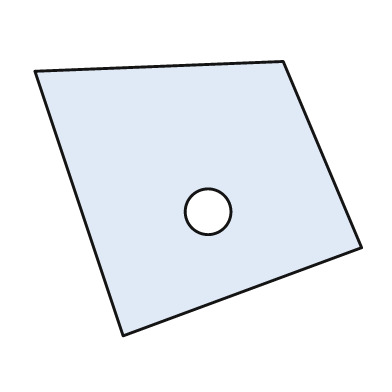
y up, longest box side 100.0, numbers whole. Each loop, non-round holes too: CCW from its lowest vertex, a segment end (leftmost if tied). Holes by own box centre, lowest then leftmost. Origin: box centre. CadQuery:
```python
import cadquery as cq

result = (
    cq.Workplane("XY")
    .moveTo(-23.0, -42.0)
    .lineTo(50.0, -15.0)
    .lineTo(26.0, 42.0)
    .lineTo(-50.0, 39.0)
    .close()
    .moveTo(3.0, -4.0)
    .circle(7.0)
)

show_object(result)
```